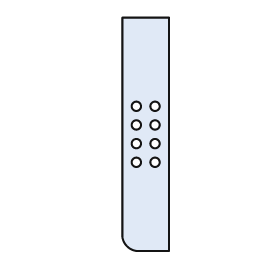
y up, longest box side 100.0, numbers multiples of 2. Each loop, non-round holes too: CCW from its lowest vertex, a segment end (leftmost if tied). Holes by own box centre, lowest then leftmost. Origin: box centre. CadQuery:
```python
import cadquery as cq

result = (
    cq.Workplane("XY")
    .moveTo(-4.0, -50.0)
    .lineTo(10.0, -50.0)
    .lineTo(10.0, 50.0)
    .lineTo(-10.0, 50.0)
    .lineTo(-10.0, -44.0)
    .threePointArc((-8.0, -48.0), (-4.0, -50.0))
    .close()
    .moveTo(-4.0, -12.0)
    .circle(2.0)
    .moveTo(4.0, -12.0)
    .circle(2.0)
    .moveTo(-4.0, -4.0)
    .circle(2.0)
    .moveTo(4.0, -4.0)
    .circle(2.0)
    .moveTo(-4.0, 4.0)
    .circle(2.0)
    .moveTo(4.0, 4.0)
    .circle(2.0)
    .moveTo(-4.0, 12.0)
    .circle(2.0)
    .moveTo(4.0, 12.0)
    .circle(2.0)
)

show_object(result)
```